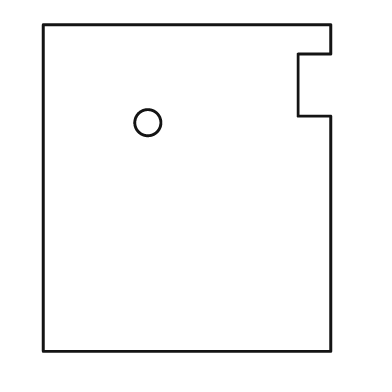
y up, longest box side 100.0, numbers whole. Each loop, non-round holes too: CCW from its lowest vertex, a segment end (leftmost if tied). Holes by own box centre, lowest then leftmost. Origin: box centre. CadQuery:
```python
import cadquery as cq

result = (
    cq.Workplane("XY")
    .moveTo(-44.0, -50.0)
    .lineTo(44.0, -50.0)
    .lineTo(44.0, 22.0)
    .lineTo(34.0, 22.0)
    .lineTo(34.0, 41.0)
    .lineTo(44.0, 41.0)
    .lineTo(44.0, 50.0)
    .lineTo(-44.0, 50.0)
    .close()
    .moveTo(-12.0, 20.0)
    .circle(4.0)
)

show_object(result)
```